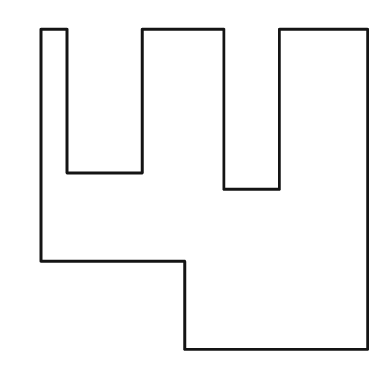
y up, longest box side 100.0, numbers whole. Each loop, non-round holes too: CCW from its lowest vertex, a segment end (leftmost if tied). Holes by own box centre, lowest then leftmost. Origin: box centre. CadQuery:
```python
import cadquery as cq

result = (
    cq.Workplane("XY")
    .moveTo(-6.0, -49.0)
    .lineTo(50.0, -49.0)
    .lineTo(50.0, 49.0)
    .lineTo(23.0, 49.0)
    .lineTo(23.0, 0.0)
    .lineTo(6.0, 0.0)
    .lineTo(6.0, 49.0)
    .lineTo(-19.0, 49.0)
    .lineTo(-19.0, 5.0)
    .lineTo(-42.0, 5.0)
    .lineTo(-42.0, 49.0)
    .lineTo(-50.0, 49.0)
    .lineTo(-50.0, -22.0)
    .lineTo(-6.0, -22.0)
    .close()
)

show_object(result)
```